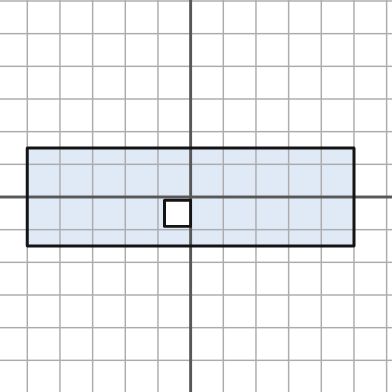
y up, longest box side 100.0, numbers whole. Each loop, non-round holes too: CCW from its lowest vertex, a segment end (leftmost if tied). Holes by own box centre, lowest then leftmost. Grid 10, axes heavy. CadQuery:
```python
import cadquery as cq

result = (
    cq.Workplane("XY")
    .moveTo(-50.0, -15.0)
    .lineTo(50.0, -15.0)
    .lineTo(50.0, 15.0)
    .lineTo(-50.0, 15.0)
    .close()
    .moveTo(-8.0, -9.0)
    .lineTo(0.0, -9.0)
    .lineTo(0.0, -1.0)
    .lineTo(-8.0, -1.0)
    .close()
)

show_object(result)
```